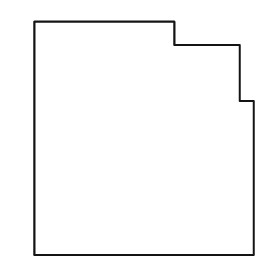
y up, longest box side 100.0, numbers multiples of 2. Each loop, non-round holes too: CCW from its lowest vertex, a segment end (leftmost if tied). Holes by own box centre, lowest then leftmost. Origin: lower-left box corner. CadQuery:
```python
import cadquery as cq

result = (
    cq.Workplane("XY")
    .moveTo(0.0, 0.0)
    .lineTo(94.0, 0.0)
    .lineTo(94.0, 66.0)
    .lineTo(88.0, 66.0)
    .lineTo(88.0, 90.0)
    .lineTo(60.0, 90.0)
    .lineTo(60.0, 100.0)
    .lineTo(0.0, 100.0)
    .close()
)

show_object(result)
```